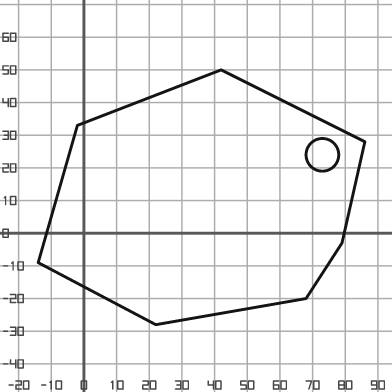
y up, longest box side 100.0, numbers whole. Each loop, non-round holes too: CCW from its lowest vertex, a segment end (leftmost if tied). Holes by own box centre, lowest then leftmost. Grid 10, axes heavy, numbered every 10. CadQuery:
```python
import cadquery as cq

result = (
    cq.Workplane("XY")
    .moveTo(22.0, -28.0)
    .lineTo(68.0, -20.0)
    .lineTo(79.0, -3.0)
    .lineTo(86.0, 28.0)
    .lineTo(42.0, 50.0)
    .lineTo(-2.0, 33.0)
    .lineTo(-14.0, -9.0)
    .close()
    .moveTo(73.0, 24.0)
    .circle(5.0)
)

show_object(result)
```